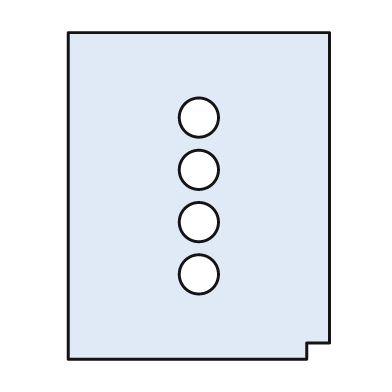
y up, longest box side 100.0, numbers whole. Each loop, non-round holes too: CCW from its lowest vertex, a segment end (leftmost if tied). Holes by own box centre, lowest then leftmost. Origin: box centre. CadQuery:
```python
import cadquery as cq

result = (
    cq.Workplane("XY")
    .moveTo(-40.0, -50.0)
    .lineTo(33.0, -50.0)
    .lineTo(33.0, -45.0)
    .lineTo(40.0, -45.0)
    .lineTo(40.0, 50.0)
    .lineTo(-40.0, 50.0)
    .close()
    .moveTo(0.0, -24.0)
    .circle(6.0)
    .moveTo(0.0, -8.0)
    .circle(6.0)
    .moveTo(0.0, 8.0)
    .circle(6.0)
    .moveTo(0.0, 24.0)
    .circle(6.0)
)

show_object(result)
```